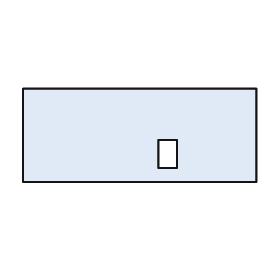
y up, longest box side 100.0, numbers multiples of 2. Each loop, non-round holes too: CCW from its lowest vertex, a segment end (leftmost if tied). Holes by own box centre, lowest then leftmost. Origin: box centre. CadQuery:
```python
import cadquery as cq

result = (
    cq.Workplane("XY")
    .moveTo(-50.0, -20.0)
    .lineTo(50.0, -20.0)
    .lineTo(50.0, 20.0)
    .lineTo(-50.0, 20.0)
    .close()
    .moveTo(8.0, -14.0)
    .lineTo(16.0, -14.0)
    .lineTo(16.0, -2.0)
    .lineTo(8.0, -2.0)
    .close()
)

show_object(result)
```